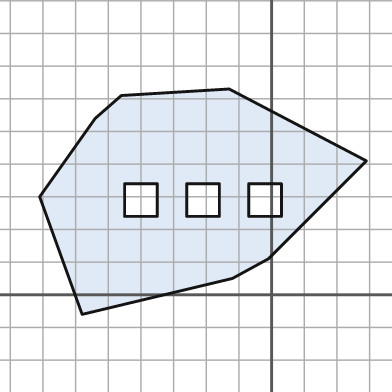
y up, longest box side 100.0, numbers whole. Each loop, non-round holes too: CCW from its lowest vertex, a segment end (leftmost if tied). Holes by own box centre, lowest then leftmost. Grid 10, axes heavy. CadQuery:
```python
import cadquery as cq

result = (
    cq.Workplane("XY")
    .moveTo(-58.0, -6.0)
    .lineTo(-12.0, 5.0)
    .lineTo(-1.0, 11.0)
    .lineTo(29.0, 41.0)
    .lineTo(-13.0, 63.0)
    .lineTo(-46.0, 61.0)
    .lineTo(-54.0, 54.0)
    .lineTo(-71.0, 30.0)
    .close()
    .moveTo(-45.0, 24.0)
    .lineTo(-35.0, 24.0)
    .lineTo(-35.0, 34.0)
    .lineTo(-45.0, 34.0)
    .close()
    .moveTo(-26.0, 24.0)
    .lineTo(-16.0, 24.0)
    .lineTo(-16.0, 34.0)
    .lineTo(-26.0, 34.0)
    .close()
    .moveTo(-7.0, 24.0)
    .lineTo(3.0, 24.0)
    .lineTo(3.0, 34.0)
    .lineTo(-7.0, 34.0)
    .close()
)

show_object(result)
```